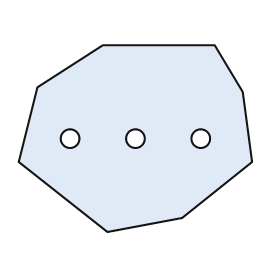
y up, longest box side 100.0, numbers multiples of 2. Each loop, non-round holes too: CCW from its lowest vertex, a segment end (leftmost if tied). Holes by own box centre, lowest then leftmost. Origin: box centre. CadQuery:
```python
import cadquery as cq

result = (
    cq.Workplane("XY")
    .moveTo(-12.0, -40.0)
    .lineTo(20.0, -34.0)
    .lineTo(50.0, -10.0)
    .lineTo(46.0, 20.0)
    .lineTo(34.0, 40.0)
    .lineTo(-14.0, 40.0)
    .lineTo(-42.0, 22.0)
    .lineTo(-50.0, -10.0)
    .close()
    .moveTo(-28.0, 0.0)
    .circle(4.0)
    .moveTo(0.0, 0.0)
    .circle(4.0)
    .moveTo(28.0, 0.0)
    .circle(4.0)
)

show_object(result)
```